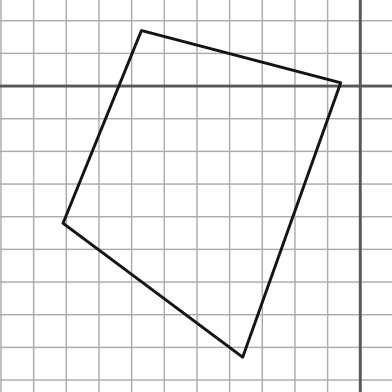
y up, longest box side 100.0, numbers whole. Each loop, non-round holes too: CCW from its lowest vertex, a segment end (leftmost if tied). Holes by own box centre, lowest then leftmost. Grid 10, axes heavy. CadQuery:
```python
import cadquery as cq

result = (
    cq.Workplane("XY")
    .moveTo(-36.0, -83.0)
    .lineTo(-6.0, 1.0)
    .lineTo(-67.0, 17.0)
    .lineTo(-91.0, -42.0)
    .close()
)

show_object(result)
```